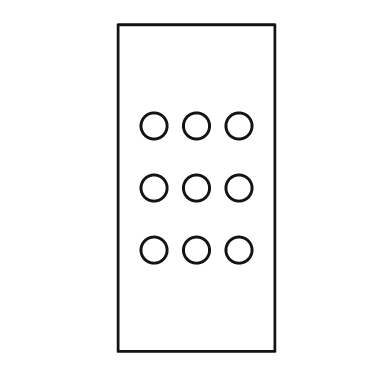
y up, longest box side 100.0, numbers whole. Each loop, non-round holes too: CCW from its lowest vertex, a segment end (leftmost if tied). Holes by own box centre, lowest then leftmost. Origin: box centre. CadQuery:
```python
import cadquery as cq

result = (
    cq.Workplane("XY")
    .moveTo(-24.0, -50.0)
    .lineTo(24.0, -50.0)
    .lineTo(24.0, 50.0)
    .lineTo(-24.0, 50.0)
    .close()
    .moveTo(-13.0, -19.0)
    .circle(4.0)
    .moveTo(0.0, -19.0)
    .circle(4.0)
    .moveTo(13.0, -19.0)
    .circle(4.0)
    .moveTo(-13.0, 0.0)
    .circle(4.0)
    .moveTo(0.0, 0.0)
    .circle(4.0)
    .moveTo(13.0, 0.0)
    .circle(4.0)
    .moveTo(-13.0, 19.0)
    .circle(4.0)
    .moveTo(0.0, 19.0)
    .circle(4.0)
    .moveTo(13.0, 19.0)
    .circle(4.0)
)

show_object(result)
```